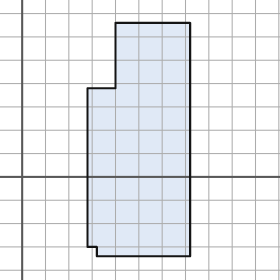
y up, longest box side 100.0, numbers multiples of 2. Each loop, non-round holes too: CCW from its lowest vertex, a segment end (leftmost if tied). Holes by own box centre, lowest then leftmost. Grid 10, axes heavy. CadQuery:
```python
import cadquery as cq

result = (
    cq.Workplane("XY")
    .moveTo(32.0, -34.0)
    .lineTo(72.0, -34.0)
    .lineTo(72.0, 66.0)
    .lineTo(40.0, 66.0)
    .lineTo(40.0, 38.0)
    .lineTo(28.0, 38.0)
    .lineTo(28.0, -30.0)
    .lineTo(32.0, -30.0)
    .close()
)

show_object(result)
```